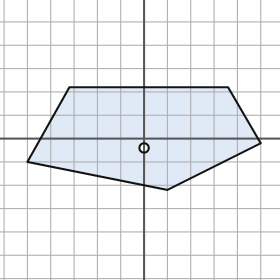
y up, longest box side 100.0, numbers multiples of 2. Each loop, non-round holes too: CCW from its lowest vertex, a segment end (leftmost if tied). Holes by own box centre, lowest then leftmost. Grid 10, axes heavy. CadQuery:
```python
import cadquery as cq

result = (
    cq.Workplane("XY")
    .moveTo(10.0, -22.0)
    .lineTo(50.0, -2.0)
    .lineTo(36.0, 22.0)
    .lineTo(-32.0, 22.0)
    .lineTo(-50.0, -10.0)
    .close()
    .moveTo(0.0, -4.0)
    .circle(2.0)
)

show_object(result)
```